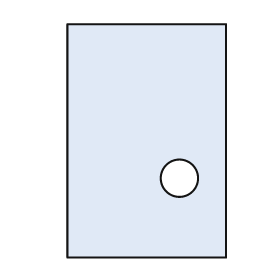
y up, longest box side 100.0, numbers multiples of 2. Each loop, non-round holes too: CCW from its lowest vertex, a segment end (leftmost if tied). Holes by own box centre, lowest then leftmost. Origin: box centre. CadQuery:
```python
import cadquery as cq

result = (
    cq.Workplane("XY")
    .moveTo(-34.0, -50.0)
    .lineTo(34.0, -50.0)
    .lineTo(34.0, 50.0)
    .lineTo(-34.0, 50.0)
    .close()
    .moveTo(14.0, -16.0)
    .circle(8.0)
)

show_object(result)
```